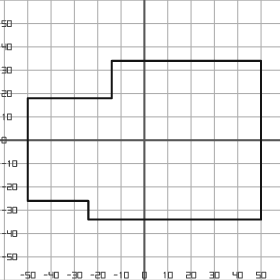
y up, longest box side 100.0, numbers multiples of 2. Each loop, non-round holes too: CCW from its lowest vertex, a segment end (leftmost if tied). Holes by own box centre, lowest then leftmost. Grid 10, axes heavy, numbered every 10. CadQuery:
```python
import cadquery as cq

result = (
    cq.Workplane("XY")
    .moveTo(-24.0, -34.0)
    .lineTo(50.0, -34.0)
    .lineTo(50.0, 34.0)
    .lineTo(-14.0, 34.0)
    .lineTo(-14.0, 18.0)
    .lineTo(-50.0, 18.0)
    .lineTo(-50.0, -26.0)
    .lineTo(-24.0, -26.0)
    .close()
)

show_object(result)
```